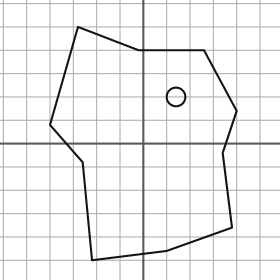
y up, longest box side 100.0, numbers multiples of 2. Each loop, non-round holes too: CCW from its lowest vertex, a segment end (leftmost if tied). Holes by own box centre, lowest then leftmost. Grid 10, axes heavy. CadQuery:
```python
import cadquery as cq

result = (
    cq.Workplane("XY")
    .moveTo(-22.0, -50.0)
    .lineTo(10.0, -46.0)
    .lineTo(38.0, -36.0)
    .lineTo(34.0, -4.0)
    .lineTo(40.0, 14.0)
    .lineTo(26.0, 40.0)
    .lineTo(-2.0, 40.0)
    .lineTo(-28.0, 50.0)
    .lineTo(-40.0, 8.0)
    .lineTo(-26.0, -8.0)
    .close()
    .moveTo(14.0, 20.0)
    .circle(4.0)
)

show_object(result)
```